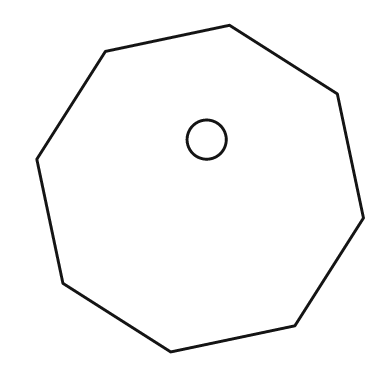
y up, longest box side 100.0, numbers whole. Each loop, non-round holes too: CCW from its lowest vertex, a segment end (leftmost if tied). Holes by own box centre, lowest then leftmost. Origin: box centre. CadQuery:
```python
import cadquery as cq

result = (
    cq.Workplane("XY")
    .moveTo(-9.0, -50.0)
    .lineTo(29.0, -42.0)
    .lineTo(50.0, -9.0)
    .lineTo(42.0, 29.0)
    .lineTo(9.0, 50.0)
    .lineTo(-29.0, 42.0)
    .lineTo(-50.0, 9.0)
    .lineTo(-42.0, -29.0)
    .close()
    .moveTo(2.0, 15.0)
    .circle(6.0)
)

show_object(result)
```